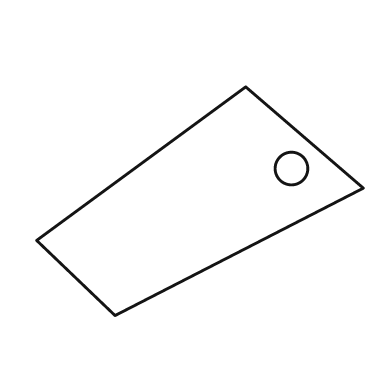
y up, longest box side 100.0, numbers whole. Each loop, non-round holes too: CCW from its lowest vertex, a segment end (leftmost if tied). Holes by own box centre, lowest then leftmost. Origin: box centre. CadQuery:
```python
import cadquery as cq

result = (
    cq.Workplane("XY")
    .moveTo(-26.0, -35.0)
    .lineTo(50.0, 4.0)
    .lineTo(14.0, 35.0)
    .lineTo(-50.0, -12.0)
    .close()
    .moveTo(28.0, 10.0)
    .circle(5.0)
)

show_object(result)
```